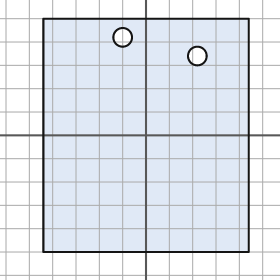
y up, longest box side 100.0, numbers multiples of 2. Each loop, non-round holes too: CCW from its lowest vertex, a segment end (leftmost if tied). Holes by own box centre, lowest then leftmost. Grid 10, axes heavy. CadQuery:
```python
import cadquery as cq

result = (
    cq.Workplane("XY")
    .moveTo(-44.0, -50.0)
    .lineTo(44.0, -50.0)
    .lineTo(44.0, 50.0)
    .lineTo(-44.0, 50.0)
    .close()
    .moveTo(22.0, 34.0)
    .circle(4.0)
    .moveTo(-10.0, 42.0)
    .circle(4.0)
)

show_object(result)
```